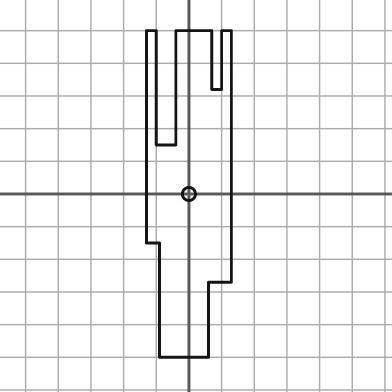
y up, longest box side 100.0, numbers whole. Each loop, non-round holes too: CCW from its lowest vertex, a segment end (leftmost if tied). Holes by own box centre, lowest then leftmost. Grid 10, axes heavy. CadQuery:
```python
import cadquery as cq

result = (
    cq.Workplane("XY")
    .moveTo(-9.0, -50.0)
    .lineTo(6.0, -50.0)
    .lineTo(6.0, -27.0)
    .lineTo(13.0, -27.0)
    .lineTo(13.0, 50.0)
    .lineTo(10.0, 50.0)
    .lineTo(10.0, 32.0)
    .lineTo(7.0, 32.0)
    .lineTo(7.0, 50.0)
    .lineTo(-4.0, 50.0)
    .lineTo(-4.0, 15.0)
    .lineTo(-10.0, 15.0)
    .lineTo(-10.0, 50.0)
    .lineTo(-13.0, 50.0)
    .lineTo(-13.0, -15.0)
    .lineTo(-9.0, -15.0)
    .close()
    .moveTo(0.0, 0.0)
    .circle(2.0)
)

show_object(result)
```